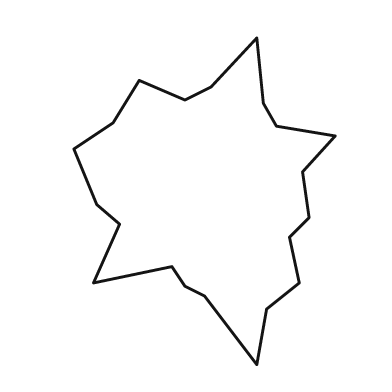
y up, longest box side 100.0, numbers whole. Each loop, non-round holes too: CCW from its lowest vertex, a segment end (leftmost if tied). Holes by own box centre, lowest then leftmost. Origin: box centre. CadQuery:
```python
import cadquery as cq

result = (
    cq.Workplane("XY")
    .moveTo(16.0, -50.0)
    .lineTo(19.0, -33.0)
    .lineTo(29.0, -25.0)
    .lineTo(26.0, -11.0)
    .lineTo(32.0, -5.0)
    .lineTo(30.0, 9.0)
    .lineTo(40.0, 20.0)
    .lineTo(22.0, 23.0)
    .lineTo(18.0, 30.0)
    .lineTo(16.0, 50.0)
    .lineTo(2.0, 35.0)
    .lineTo(-6.0, 31.0)
    .lineTo(-20.0, 37.0)
    .lineTo(-28.0, 24.0)
    .lineTo(-40.0, 16.0)
    .lineTo(-33.0, -1.0)
    .lineTo(-26.0, -7.0)
    .lineTo(-34.0, -25.0)
    .lineTo(-10.0, -20.0)
    .lineTo(-6.0, -26.0)
    .lineTo(0.0, -29.0)
    .close()
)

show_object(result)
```